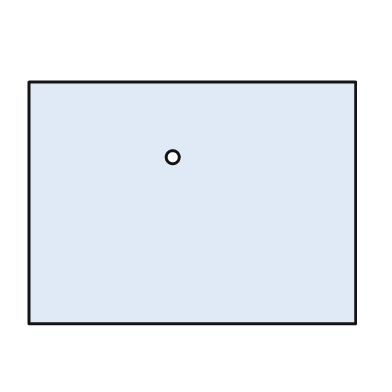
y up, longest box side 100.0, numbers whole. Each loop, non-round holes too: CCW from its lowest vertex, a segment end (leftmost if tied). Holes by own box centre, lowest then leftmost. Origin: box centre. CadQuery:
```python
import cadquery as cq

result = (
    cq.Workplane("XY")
    .moveTo(-50.0, -37.0)
    .lineTo(50.0, -37.0)
    .lineTo(50.0, 37.0)
    .lineTo(-50.0, 37.0)
    .close()
    .moveTo(-6.0, 14.0)
    .circle(2.0)
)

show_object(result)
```